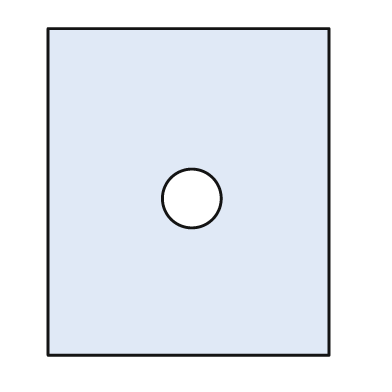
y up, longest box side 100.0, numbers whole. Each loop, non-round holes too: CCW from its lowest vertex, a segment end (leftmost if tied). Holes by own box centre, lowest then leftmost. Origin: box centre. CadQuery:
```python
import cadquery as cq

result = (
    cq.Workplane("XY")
    .moveTo(-43.0, -50.0)
    .lineTo(43.0, -50.0)
    .lineTo(43.0, 50.0)
    .lineTo(-43.0, 50.0)
    .close()
    .moveTo(1.0, -2.0)
    .circle(9.0)
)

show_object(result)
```